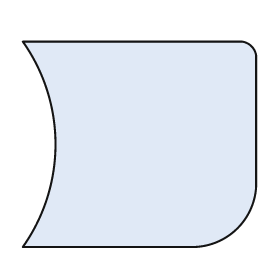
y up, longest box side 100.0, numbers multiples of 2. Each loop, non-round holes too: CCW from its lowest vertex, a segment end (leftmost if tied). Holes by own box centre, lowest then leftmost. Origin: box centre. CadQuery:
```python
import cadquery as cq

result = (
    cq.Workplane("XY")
    .moveTo(-50.0, -44.0)
    .lineTo(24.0, -44.0)
    .threePointArc((42.0, -36.0), (50.0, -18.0))
    .lineTo(50.0, 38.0)
    .threePointArc((48.0, 42.0), (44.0, 44.0))
    .lineTo(-50.0, 44.0)
    .threePointArc((-36.0, 0.0), (-50.0, -44.0))
    .close()
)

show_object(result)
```